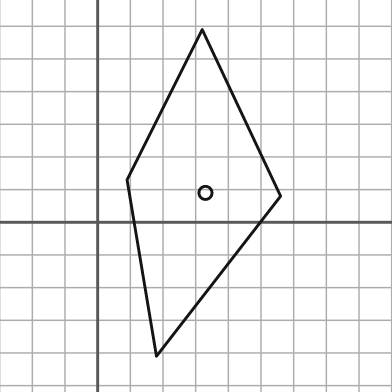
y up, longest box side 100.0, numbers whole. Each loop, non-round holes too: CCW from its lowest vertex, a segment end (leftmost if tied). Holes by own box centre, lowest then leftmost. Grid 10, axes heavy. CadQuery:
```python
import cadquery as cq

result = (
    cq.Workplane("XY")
    .moveTo(18.0, -41.0)
    .lineTo(56.0, 8.0)
    .lineTo(32.0, 59.0)
    .lineTo(9.0, 13.0)
    .close()
    .moveTo(33.0, 9.0)
    .circle(2.0)
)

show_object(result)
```